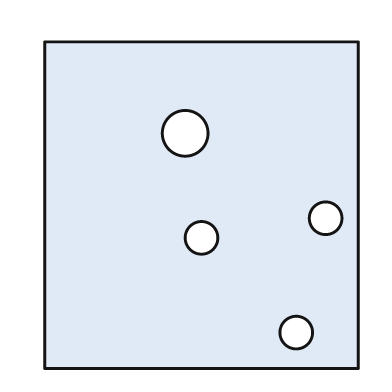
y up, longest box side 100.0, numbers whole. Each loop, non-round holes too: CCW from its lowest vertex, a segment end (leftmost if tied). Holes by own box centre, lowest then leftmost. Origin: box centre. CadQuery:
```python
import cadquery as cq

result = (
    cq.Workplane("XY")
    .moveTo(-48.0, -50.0)
    .lineTo(48.0, -50.0)
    .lineTo(48.0, 50.0)
    .lineTo(-48.0, 50.0)
    .close()
    .moveTo(29.0, -39.0)
    .circle(5.0)
    .moveTo(0.0, -10.0)
    .circle(5.0)
    .moveTo(38.0, -4.0)
    .circle(5.0)
    .moveTo(-5.0, 22.0)
    .circle(7.0)
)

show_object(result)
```